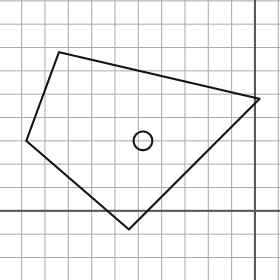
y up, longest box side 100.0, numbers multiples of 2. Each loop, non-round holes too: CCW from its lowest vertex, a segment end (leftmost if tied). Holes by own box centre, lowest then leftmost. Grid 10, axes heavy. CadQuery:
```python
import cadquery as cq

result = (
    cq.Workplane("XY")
    .moveTo(-54.0, -8.0)
    .lineTo(2.0, 48.0)
    .lineTo(-84.0, 68.0)
    .lineTo(-98.0, 30.0)
    .close()
    .moveTo(-48.0, 30.0)
    .circle(4.0)
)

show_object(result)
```